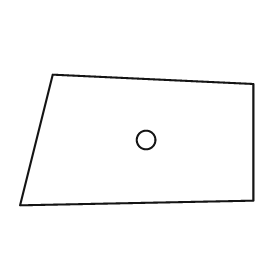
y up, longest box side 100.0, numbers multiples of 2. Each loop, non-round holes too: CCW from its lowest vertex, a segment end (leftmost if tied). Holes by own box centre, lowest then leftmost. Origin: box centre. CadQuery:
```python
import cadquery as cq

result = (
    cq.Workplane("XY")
    .moveTo(-50.0, -28.0)
    .lineTo(50.0, -26.0)
    .lineTo(50.0, 24.0)
    .lineTo(-36.0, 28.0)
    .close()
    .moveTo(4.0, 0.0)
    .circle(4.0)
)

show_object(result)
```